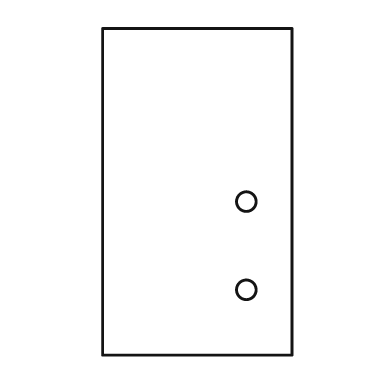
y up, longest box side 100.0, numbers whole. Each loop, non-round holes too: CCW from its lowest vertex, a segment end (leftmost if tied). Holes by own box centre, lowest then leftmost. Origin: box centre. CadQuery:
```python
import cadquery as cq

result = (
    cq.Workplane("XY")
    .moveTo(-29.0, -50.0)
    .lineTo(29.0, -50.0)
    .lineTo(29.0, 50.0)
    .lineTo(-29.0, 50.0)
    .close()
    .moveTo(15.0, -30.0)
    .circle(3.0)
    .moveTo(15.0, -3.0)
    .circle(3.0)
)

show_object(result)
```